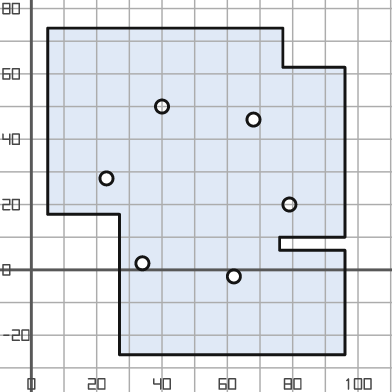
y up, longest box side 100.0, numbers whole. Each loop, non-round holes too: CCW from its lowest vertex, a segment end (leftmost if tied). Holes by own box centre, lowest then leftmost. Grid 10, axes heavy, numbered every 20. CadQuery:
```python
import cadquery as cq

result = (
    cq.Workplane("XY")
    .moveTo(27.0, -26.0)
    .lineTo(96.0, -26.0)
    .lineTo(96.0, 6.0)
    .lineTo(76.0, 6.0)
    .lineTo(76.0, 10.0)
    .lineTo(96.0, 10.0)
    .lineTo(96.0, 62.0)
    .lineTo(77.0, 62.0)
    .lineTo(77.0, 74.0)
    .lineTo(5.0, 74.0)
    .lineTo(5.0, 17.0)
    .lineTo(27.0, 17.0)
    .close()
    .moveTo(62.0, -2.0)
    .circle(2.0)
    .moveTo(34.0, 2.0)
    .circle(2.0)
    .moveTo(79.0, 20.0)
    .circle(2.0)
    .moveTo(23.0, 28.0)
    .circle(2.0)
    .moveTo(68.0, 46.0)
    .circle(2.0)
    .moveTo(40.0, 50.0)
    .circle(2.0)
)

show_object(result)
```